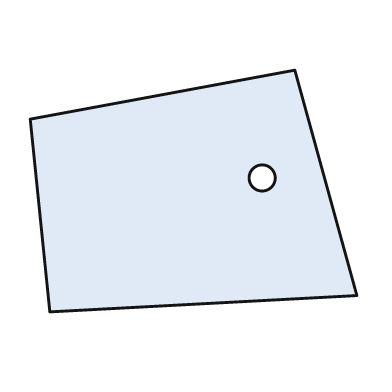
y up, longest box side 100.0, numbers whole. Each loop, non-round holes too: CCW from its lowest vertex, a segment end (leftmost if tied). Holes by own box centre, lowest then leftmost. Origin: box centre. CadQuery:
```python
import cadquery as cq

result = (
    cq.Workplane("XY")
    .moveTo(-44.0, -37.0)
    .lineTo(50.0, -32.0)
    .lineTo(31.0, 37.0)
    .lineTo(-50.0, 22.0)
    .close()
    .moveTo(21.0, 4.0)
    .circle(4.0)
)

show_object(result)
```